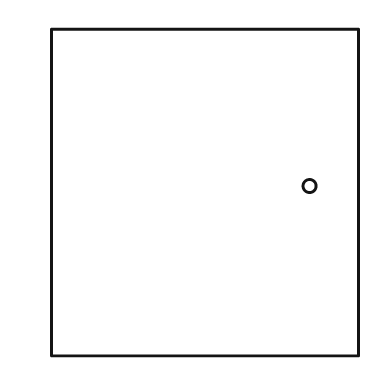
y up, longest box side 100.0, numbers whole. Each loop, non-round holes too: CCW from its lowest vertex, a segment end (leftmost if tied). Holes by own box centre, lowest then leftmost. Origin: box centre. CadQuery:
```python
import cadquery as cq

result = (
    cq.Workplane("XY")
    .moveTo(-47.0, -50.0)
    .lineTo(47.0, -50.0)
    .lineTo(47.0, 50.0)
    .lineTo(-47.0, 50.0)
    .close()
    .moveTo(32.0, 2.0)
    .circle(2.0)
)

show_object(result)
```